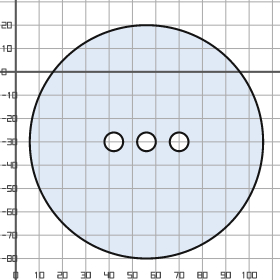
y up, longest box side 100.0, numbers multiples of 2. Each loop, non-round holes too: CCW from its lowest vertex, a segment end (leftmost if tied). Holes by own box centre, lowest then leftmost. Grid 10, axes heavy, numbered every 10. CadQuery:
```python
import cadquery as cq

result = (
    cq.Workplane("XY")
    .moveTo(56.0, -30.0)
    .circle(50.0)
    .moveTo(42.0, -30.0)
    .circle(4.0)
    .moveTo(56.0, -30.0)
    .circle(4.0)
    .moveTo(70.0, -30.0)
    .circle(4.0)
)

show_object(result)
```